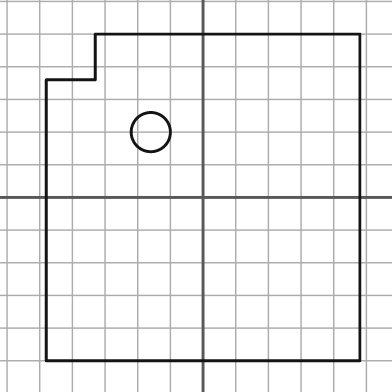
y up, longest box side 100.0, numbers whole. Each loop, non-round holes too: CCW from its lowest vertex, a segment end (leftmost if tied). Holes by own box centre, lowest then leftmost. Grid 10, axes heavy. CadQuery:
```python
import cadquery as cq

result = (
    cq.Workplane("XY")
    .moveTo(-48.0, -50.0)
    .lineTo(48.0, -50.0)
    .lineTo(48.0, 50.0)
    .lineTo(-33.0, 50.0)
    .lineTo(-33.0, 36.0)
    .lineTo(-48.0, 36.0)
    .close()
    .moveTo(-16.0, 20.0)
    .circle(6.0)
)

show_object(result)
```